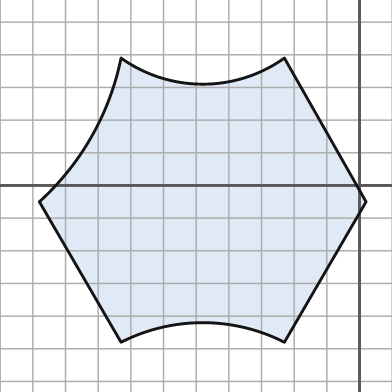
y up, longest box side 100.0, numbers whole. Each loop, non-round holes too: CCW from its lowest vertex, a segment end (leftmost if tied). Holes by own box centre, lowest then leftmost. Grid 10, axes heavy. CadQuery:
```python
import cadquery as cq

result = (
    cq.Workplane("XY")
    .moveTo(-73.0, -48.0)
    .threePointArc((-48.0, -42.0), (-23.0, -48.0))
    .lineTo(2.0, -5.0)
    .lineTo(-23.0, 39.0)
    .threePointArc((-48.0, 31.0), (-73.0, 39.0))
    .threePointArc((-82.0, 15.0), (-98.0, -5.0))
    .close()
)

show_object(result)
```